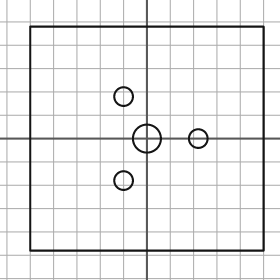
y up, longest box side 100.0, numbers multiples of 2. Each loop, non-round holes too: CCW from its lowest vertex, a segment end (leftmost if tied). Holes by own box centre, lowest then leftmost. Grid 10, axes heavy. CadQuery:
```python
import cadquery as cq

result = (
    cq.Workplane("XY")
    .moveTo(-50.0, -48.0)
    .lineTo(50.0, -48.0)
    .lineTo(50.0, 48.0)
    .lineTo(-50.0, 48.0)
    .close()
    .moveTo(-10.0, -18.0)
    .circle(4.0)
    .moveTo(0.0, 0.0)
    .circle(6.0)
    .moveTo(22.0, 0.0)
    .circle(4.0)
    .moveTo(-10.0, 18.0)
    .circle(4.0)
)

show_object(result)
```